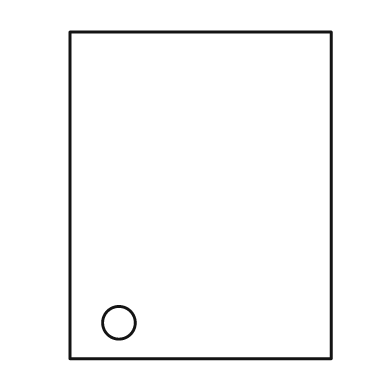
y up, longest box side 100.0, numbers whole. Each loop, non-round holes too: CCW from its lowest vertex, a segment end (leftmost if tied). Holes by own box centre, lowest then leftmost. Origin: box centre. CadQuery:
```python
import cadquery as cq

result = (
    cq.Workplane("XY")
    .moveTo(-40.0, -50.0)
    .lineTo(40.0, -50.0)
    .lineTo(40.0, 50.0)
    .lineTo(-40.0, 50.0)
    .close()
    .moveTo(-25.0, -39.0)
    .circle(5.0)
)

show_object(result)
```